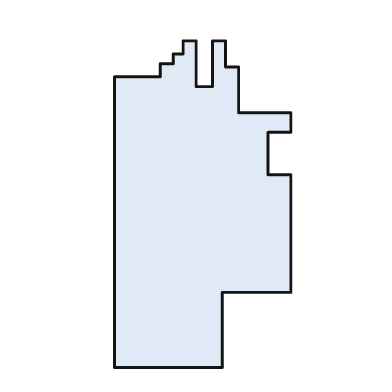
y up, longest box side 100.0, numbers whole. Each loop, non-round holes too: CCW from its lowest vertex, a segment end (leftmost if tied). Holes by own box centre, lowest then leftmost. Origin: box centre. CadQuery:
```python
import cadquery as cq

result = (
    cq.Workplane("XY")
    .moveTo(-27.0, -50.0)
    .lineTo(6.0, -50.0)
    .lineTo(6.0, -27.0)
    .lineTo(27.0, -27.0)
    .lineTo(27.0, 9.0)
    .lineTo(20.0, 9.0)
    .lineTo(20.0, 22.0)
    .lineTo(27.0, 22.0)
    .lineTo(27.0, 28.0)
    .lineTo(11.0, 28.0)
    .lineTo(11.0, 42.0)
    .lineTo(7.0, 42.0)
    .lineTo(7.0, 50.0)
    .lineTo(3.0, 50.0)
    .lineTo(3.0, 36.0)
    .lineTo(-2.0, 36.0)
    .lineTo(-2.0, 50.0)
    .lineTo(-6.0, 50.0)
    .lineTo(-6.0, 46.0)
    .lineTo(-9.0, 46.0)
    .lineTo(-9.0, 43.0)
    .lineTo(-13.0, 43.0)
    .lineTo(-13.0, 39.0)
    .lineTo(-27.0, 39.0)
    .close()
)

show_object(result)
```